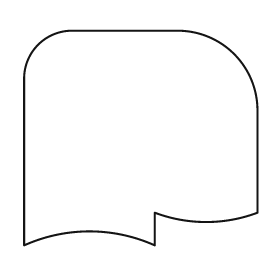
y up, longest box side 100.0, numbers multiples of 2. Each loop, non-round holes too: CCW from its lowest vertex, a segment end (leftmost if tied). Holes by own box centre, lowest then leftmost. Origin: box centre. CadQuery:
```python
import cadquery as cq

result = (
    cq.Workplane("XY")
    .moveTo(-50.0, -46.0)
    .threePointArc((-22.0, -40.0), (6.0, -46.0))
    .lineTo(6.0, -32.0)
    .threePointArc((28.0, -36.0), (50.0, -32.0))
    .lineTo(50.0, 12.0)
    .threePointArc((40.0, 36.0), (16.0, 46.0))
    .lineTo(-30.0, 46.0)
    .threePointArc((-44.0, 40.0), (-50.0, 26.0))
    .close()
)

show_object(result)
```